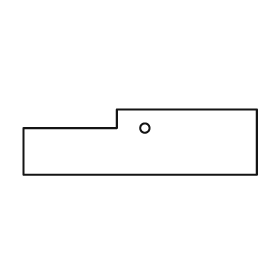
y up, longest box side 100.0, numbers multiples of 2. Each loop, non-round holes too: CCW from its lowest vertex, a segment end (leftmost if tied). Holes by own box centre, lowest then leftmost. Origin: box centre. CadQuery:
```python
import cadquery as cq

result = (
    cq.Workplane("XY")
    .moveTo(-50.0, -14.0)
    .lineTo(50.0, -14.0)
    .lineTo(50.0, 14.0)
    .lineTo(-10.0, 14.0)
    .lineTo(-10.0, 6.0)
    .lineTo(-50.0, 6.0)
    .close()
    .moveTo(2.0, 6.0)
    .circle(2.0)
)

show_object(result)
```